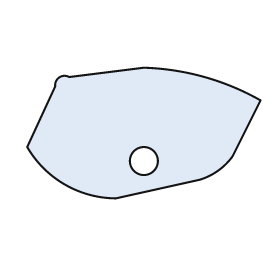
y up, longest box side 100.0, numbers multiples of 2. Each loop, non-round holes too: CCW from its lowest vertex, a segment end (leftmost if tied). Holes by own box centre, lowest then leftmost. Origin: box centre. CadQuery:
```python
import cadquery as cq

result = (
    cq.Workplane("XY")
    .moveTo(-12.0, -28.0)
    .lineTo(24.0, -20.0)
    .threePointArc((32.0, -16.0), (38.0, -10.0))
    .lineTo(50.0, 14.0)
    .threePointArc((26.0, 24.0), (0.0, 28.0))
    .lineTo(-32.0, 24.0)
    .threePointArc((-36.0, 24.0), (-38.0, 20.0))
    .lineTo(-50.0, -6.0)
    .threePointArc((-34.0, -22.0), (-12.0, -28.0))
    .close()
    .moveTo(0.0, -12.0)
    .circle(6.0)
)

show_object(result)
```